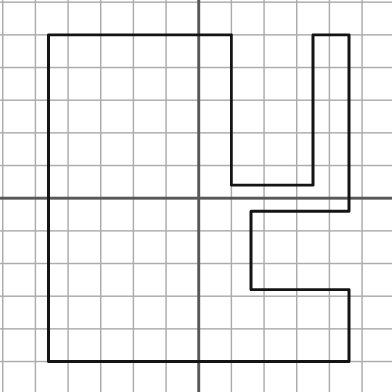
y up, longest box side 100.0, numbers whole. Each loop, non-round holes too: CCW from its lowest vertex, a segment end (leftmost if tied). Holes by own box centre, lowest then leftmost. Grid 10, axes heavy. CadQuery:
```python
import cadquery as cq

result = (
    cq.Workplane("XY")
    .moveTo(-46.0, -50.0)
    .lineTo(46.0, -50.0)
    .lineTo(46.0, -28.0)
    .lineTo(16.0, -28.0)
    .lineTo(16.0, -4.0)
    .lineTo(46.0, -4.0)
    .lineTo(46.0, 50.0)
    .lineTo(35.0, 50.0)
    .lineTo(35.0, 4.0)
    .lineTo(10.0, 4.0)
    .lineTo(10.0, 50.0)
    .lineTo(-46.0, 50.0)
    .close()
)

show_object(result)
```